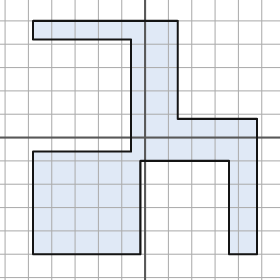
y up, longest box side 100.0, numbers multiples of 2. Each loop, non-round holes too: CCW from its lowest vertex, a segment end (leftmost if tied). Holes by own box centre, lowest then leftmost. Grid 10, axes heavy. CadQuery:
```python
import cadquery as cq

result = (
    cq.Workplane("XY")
    .moveTo(-48.0, -50.0)
    .lineTo(-2.0, -50.0)
    .lineTo(-2.0, -10.0)
    .lineTo(36.0, -10.0)
    .lineTo(36.0, -50.0)
    .lineTo(48.0, -50.0)
    .lineTo(48.0, 8.0)
    .lineTo(14.0, 8.0)
    .lineTo(14.0, 50.0)
    .lineTo(-48.0, 50.0)
    .lineTo(-48.0, 42.0)
    .lineTo(-6.0, 42.0)
    .lineTo(-6.0, -6.0)
    .lineTo(-48.0, -6.0)
    .close()
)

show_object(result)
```